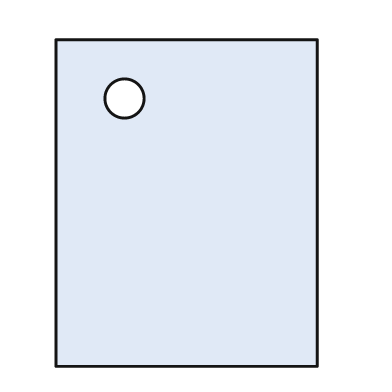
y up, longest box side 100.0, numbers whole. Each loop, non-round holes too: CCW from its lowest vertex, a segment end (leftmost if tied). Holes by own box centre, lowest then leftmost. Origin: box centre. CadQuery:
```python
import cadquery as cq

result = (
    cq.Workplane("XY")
    .moveTo(-40.0, -50.0)
    .lineTo(40.0, -50.0)
    .lineTo(40.0, 50.0)
    .lineTo(-40.0, 50.0)
    .close()
    .moveTo(-19.0, 32.0)
    .circle(6.0)
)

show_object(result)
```